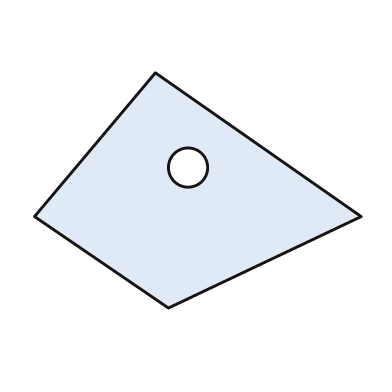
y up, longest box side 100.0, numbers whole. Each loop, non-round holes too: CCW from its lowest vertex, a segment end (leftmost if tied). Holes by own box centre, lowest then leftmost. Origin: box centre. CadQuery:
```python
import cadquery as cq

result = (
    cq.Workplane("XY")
    .moveTo(-9.0, -36.0)
    .lineTo(50.0, -8.0)
    .lineTo(-13.0, 36.0)
    .lineTo(-50.0, -8.0)
    .close()
    .moveTo(-3.0, 7.0)
    .circle(6.0)
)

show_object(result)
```